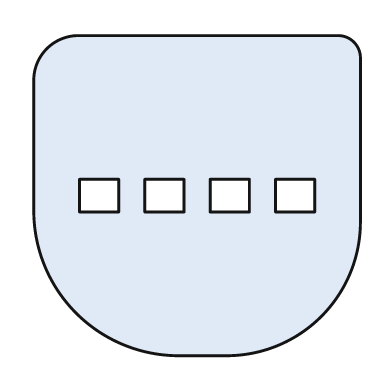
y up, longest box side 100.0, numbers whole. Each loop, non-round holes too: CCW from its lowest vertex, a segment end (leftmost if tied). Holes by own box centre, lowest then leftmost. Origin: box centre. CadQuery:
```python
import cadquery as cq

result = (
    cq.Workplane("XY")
    .moveTo(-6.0, -49.0)
    .lineTo(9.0, -49.0)
    .threePointArc((38.0, -37.0), (50.0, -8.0))
    .lineTo(50.0, 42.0)
    .threePointArc((48.0, 47.0), (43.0, 49.0))
    .lineTo(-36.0, 49.0)
    .threePointArc((-46.0, 45.0), (-50.0, 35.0))
    .lineTo(-50.0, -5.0)
    .threePointArc((-37.0, -36.0), (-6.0, -49.0))
    .close()
    .moveTo(-36.0, -5.0)
    .lineTo(-24.0, -5.0)
    .lineTo(-24.0, 5.0)
    .lineTo(-36.0, 5.0)
    .close()
    .moveTo(-16.0, -5.0)
    .lineTo(-4.0, -5.0)
    .lineTo(-4.0, 5.0)
    .lineTo(-16.0, 5.0)
    .close()
    .moveTo(4.0, -5.0)
    .lineTo(16.0, -5.0)
    .lineTo(16.0, 5.0)
    .lineTo(4.0, 5.0)
    .close()
    .moveTo(24.0, -5.0)
    .lineTo(36.0, -5.0)
    .lineTo(36.0, 5.0)
    .lineTo(24.0, 5.0)
    .close()
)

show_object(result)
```